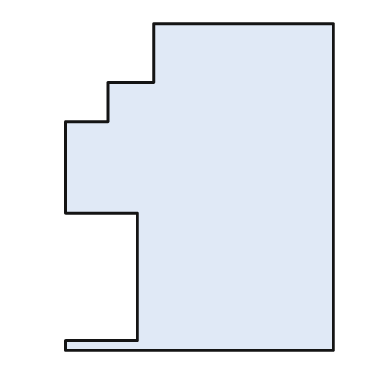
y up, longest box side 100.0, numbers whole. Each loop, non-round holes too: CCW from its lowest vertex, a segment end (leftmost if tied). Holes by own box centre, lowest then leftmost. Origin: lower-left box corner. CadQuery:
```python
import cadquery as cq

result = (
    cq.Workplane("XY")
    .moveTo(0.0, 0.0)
    .lineTo(82.0, 0.0)
    .lineTo(82.0, 100.0)
    .lineTo(27.0, 100.0)
    .lineTo(27.0, 82.0)
    .lineTo(13.0, 82.0)
    .lineTo(13.0, 70.0)
    .lineTo(0.0, 70.0)
    .lineTo(0.0, 42.0)
    .lineTo(22.0, 42.0)
    .lineTo(22.0, 3.0)
    .lineTo(0.0, 3.0)
    .close()
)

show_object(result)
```